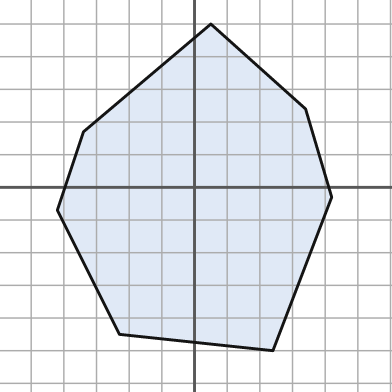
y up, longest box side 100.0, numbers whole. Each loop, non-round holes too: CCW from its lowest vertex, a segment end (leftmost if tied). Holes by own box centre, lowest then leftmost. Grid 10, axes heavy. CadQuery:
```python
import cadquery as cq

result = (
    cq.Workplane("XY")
    .moveTo(24.0, -50.0)
    .lineTo(42.0, -3.0)
    .lineTo(34.0, 24.0)
    .lineTo(5.0, 50.0)
    .lineTo(-34.0, 17.0)
    .lineTo(-42.0, -7.0)
    .lineTo(-23.0, -45.0)
    .close()
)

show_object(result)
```